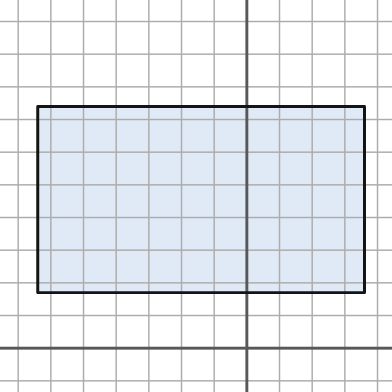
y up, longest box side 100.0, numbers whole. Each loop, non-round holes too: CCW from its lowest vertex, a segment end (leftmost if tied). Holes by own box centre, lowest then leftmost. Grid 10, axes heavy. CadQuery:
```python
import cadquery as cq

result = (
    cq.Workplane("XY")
    .moveTo(-64.0, 17.0)
    .lineTo(36.0, 17.0)
    .lineTo(36.0, 74.0)
    .lineTo(-64.0, 74.0)
    .close()
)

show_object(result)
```